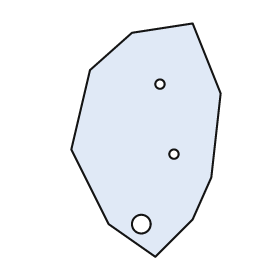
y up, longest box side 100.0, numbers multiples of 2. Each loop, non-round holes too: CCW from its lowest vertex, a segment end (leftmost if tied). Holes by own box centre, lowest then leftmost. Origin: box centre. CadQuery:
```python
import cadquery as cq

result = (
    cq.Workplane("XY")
    .moveTo(4.0, -50.0)
    .lineTo(20.0, -34.0)
    .lineTo(28.0, -16.0)
    .lineTo(32.0, 20.0)
    .lineTo(20.0, 50.0)
    .lineTo(-6.0, 46.0)
    .lineTo(-24.0, 30.0)
    .lineTo(-32.0, -4.0)
    .lineTo(-16.0, -36.0)
    .close()
    .moveTo(-2.0, -36.0)
    .circle(4.0)
    .moveTo(12.0, -6.0)
    .circle(2.0)
    .moveTo(6.0, 24.0)
    .circle(2.0)
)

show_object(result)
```